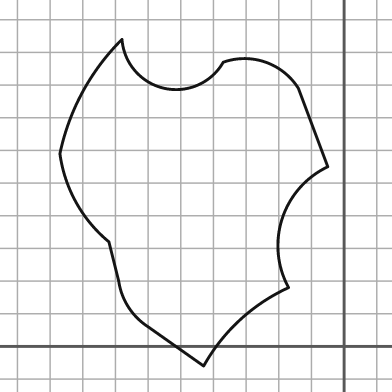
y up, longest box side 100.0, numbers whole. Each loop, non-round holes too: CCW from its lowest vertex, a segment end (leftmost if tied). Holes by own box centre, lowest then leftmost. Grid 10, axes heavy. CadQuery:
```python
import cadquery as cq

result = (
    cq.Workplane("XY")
    .moveTo(-43.0, -6.0)
    .threePointArc((-32.0, 8.0), (-17.0, 18.0))
    .threePointArc((-19.0, 39.0), (-5.0, 55.0))
    .lineTo(-14.0, 79.0)
    .threePointArc((-24.0, 87.0), (-37.0, 87.0))
    .threePointArc((-55.0, 79.0), (-68.0, 94.0))
    .threePointArc((-80.0, 78.0), (-87.0, 59.0))
    .threePointArc((-82.0, 44.0), (-72.0, 32.0))
    .lineTo(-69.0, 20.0)
    .threePointArc((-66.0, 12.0), (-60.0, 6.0))
    .close()
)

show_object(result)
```